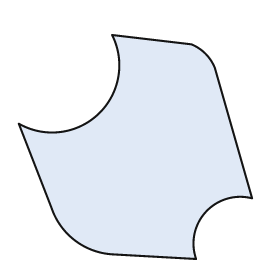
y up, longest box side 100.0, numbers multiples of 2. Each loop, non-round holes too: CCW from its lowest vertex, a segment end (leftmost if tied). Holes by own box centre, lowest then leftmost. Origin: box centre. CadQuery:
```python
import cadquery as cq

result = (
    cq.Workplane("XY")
    .moveTo(26.0, -48.0)
    .threePointArc((30.0, -28.0), (50.0, -22.0))
    .lineTo(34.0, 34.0)
    .threePointArc((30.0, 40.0), (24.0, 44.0))
    .lineTo(-10.0, 48.0)
    .threePointArc((-16.0, 14.0), (-50.0, 10.0))
    .lineTo(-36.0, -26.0)
    .threePointArc((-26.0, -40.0), (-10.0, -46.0))
    .close()
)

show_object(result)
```